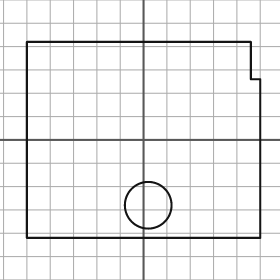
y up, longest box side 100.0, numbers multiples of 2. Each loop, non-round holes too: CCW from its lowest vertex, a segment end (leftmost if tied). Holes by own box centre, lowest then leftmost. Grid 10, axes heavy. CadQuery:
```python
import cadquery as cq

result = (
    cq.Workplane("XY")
    .moveTo(-50.0, -42.0)
    .lineTo(50.0, -42.0)
    .lineTo(50.0, 26.0)
    .lineTo(46.0, 26.0)
    .lineTo(46.0, 42.0)
    .lineTo(-50.0, 42.0)
    .close()
    .moveTo(2.0, -28.0)
    .circle(10.0)
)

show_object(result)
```